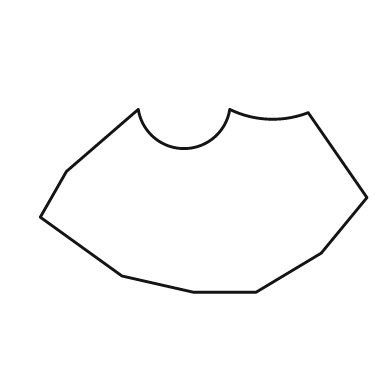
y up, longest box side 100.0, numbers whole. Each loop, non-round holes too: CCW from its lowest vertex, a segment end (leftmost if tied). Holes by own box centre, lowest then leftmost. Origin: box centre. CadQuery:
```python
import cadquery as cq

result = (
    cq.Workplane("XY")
    .moveTo(-3.0, -28.0)
    .lineTo(16.0, -28.0)
    .lineTo(36.0, -16.0)
    .lineTo(50.0, 1.0)
    .lineTo(32.0, 27.0)
    .threePointArc((20.0, 25.0), (8.0, 28.0))
    .threePointArc((-6.0, 16.0), (-20.0, 28.0))
    .lineTo(-42.0, 9.0)
    .lineTo(-50.0, -5.0)
    .lineTo(-25.0, -23.0)
    .close()
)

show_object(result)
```